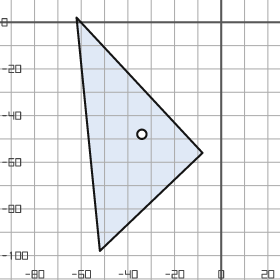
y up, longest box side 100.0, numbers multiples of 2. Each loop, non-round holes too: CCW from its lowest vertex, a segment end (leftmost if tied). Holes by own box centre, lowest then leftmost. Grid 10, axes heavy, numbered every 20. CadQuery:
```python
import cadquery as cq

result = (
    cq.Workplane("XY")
    .moveTo(-52.0, -98.0)
    .lineTo(-8.0, -56.0)
    .lineTo(-62.0, 2.0)
    .close()
    .moveTo(-34.0, -48.0)
    .circle(2.0)
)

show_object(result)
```